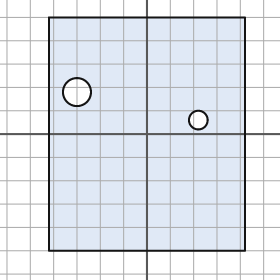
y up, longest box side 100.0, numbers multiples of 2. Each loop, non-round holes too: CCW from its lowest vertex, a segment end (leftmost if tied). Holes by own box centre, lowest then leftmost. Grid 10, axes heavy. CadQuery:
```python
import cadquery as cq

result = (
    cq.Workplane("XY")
    .moveTo(-42.0, -50.0)
    .lineTo(42.0, -50.0)
    .lineTo(42.0, 50.0)
    .lineTo(-42.0, 50.0)
    .close()
    .moveTo(22.0, 6.0)
    .circle(4.0)
    .moveTo(-30.0, 18.0)
    .circle(6.0)
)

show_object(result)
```